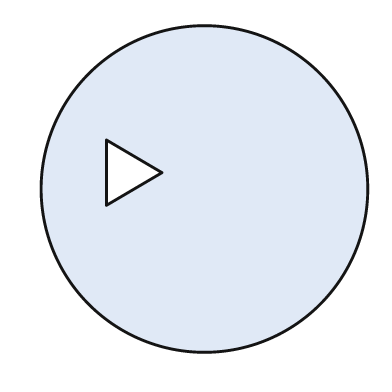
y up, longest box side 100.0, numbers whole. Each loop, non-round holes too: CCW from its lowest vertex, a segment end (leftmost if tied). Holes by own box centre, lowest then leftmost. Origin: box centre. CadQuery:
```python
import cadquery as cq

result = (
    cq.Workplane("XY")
    .moveTo(0.0, 0.0)
    .circle(50.0)
    .moveTo(-30.0, -5.0)
    .lineTo(-13.0, 5.0)
    .lineTo(-30.0, 15.0)
    .close()
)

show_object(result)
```